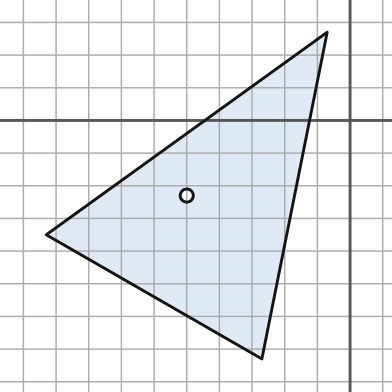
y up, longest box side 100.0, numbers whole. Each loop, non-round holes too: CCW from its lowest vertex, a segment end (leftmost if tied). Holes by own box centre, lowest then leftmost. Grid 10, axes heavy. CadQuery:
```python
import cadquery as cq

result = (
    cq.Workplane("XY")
    .moveTo(-27.0, -73.0)
    .lineTo(-7.0, 27.0)
    .lineTo(-93.0, -35.0)
    .close()
    .moveTo(-50.0, -23.0)
    .circle(2.0)
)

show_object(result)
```